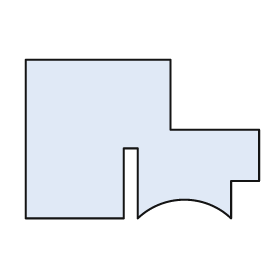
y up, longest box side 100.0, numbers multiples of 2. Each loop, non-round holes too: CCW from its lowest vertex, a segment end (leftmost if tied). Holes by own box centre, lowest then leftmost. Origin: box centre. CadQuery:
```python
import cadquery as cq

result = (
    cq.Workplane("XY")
    .moveTo(-50.0, -34.0)
    .lineTo(-8.0, -34.0)
    .lineTo(-8.0, -4.0)
    .lineTo(-2.0, -4.0)
    .lineTo(-2.0, -34.0)
    .threePointArc((18.0, -26.0), (38.0, -34.0))
    .lineTo(38.0, -18.0)
    .lineTo(50.0, -18.0)
    .lineTo(50.0, 4.0)
    .lineTo(12.0, 4.0)
    .lineTo(12.0, 34.0)
    .lineTo(-50.0, 34.0)
    .close()
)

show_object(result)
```